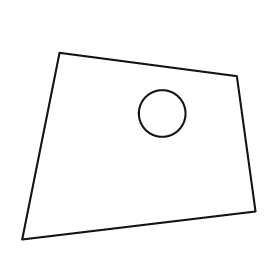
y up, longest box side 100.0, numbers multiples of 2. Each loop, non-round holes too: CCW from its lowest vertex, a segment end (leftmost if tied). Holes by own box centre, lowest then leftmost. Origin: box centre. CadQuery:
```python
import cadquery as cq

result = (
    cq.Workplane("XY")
    .moveTo(-50.0, -40.0)
    .lineTo(50.0, -28.0)
    .lineTo(42.0, 30.0)
    .lineTo(-34.0, 40.0)
    .close()
    .moveTo(10.0, 14.0)
    .circle(10.0)
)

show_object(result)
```